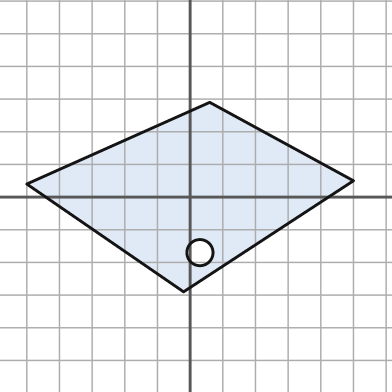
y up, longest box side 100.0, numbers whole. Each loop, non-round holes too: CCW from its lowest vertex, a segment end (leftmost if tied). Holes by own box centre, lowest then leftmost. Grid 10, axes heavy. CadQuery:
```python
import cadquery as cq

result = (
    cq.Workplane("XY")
    .moveTo(-2.0, -29.0)
    .lineTo(50.0, 5.0)
    .lineTo(6.0, 29.0)
    .lineTo(-50.0, 4.0)
    .close()
    .moveTo(3.0, -17.0)
    .circle(4.0)
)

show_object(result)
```